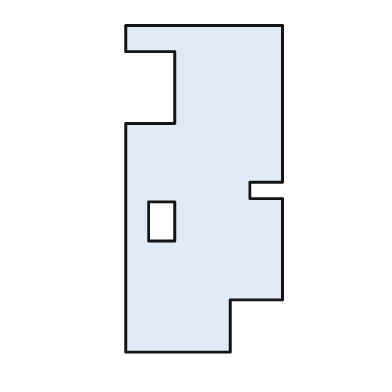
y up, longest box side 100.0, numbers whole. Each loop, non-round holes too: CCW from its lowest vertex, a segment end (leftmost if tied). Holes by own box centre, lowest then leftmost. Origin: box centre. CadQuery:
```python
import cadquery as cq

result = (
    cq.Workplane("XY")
    .moveTo(-24.0, -50.0)
    .lineTo(8.0, -50.0)
    .lineTo(8.0, -34.0)
    .lineTo(24.0, -34.0)
    .lineTo(24.0, -3.0)
    .lineTo(14.0, -3.0)
    .lineTo(14.0, 2.0)
    .lineTo(24.0, 2.0)
    .lineTo(24.0, 50.0)
    .lineTo(-24.0, 50.0)
    .lineTo(-24.0, 42.0)
    .lineTo(-9.0, 42.0)
    .lineTo(-9.0, 20.0)
    .lineTo(-24.0, 20.0)
    .close()
    .moveTo(-17.0, -16.0)
    .lineTo(-9.0, -16.0)
    .lineTo(-9.0, -4.0)
    .lineTo(-17.0, -4.0)
    .close()
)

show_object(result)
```